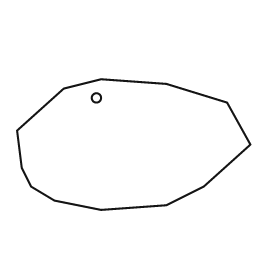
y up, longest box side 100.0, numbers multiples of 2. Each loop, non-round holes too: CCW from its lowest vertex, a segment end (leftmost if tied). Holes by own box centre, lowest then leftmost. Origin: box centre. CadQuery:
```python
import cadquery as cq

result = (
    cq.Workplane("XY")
    .moveTo(-14.0, -28.0)
    .lineTo(14.0, -26.0)
    .lineTo(30.0, -18.0)
    .lineTo(50.0, 0.0)
    .lineTo(40.0, 18.0)
    .lineTo(14.0, 26.0)
    .lineTo(-14.0, 28.0)
    .lineTo(-30.0, 24.0)
    .lineTo(-50.0, 6.0)
    .lineTo(-48.0, -10.0)
    .lineTo(-44.0, -18.0)
    .lineTo(-34.0, -24.0)
    .close()
    .moveTo(-16.0, 20.0)
    .circle(2.0)
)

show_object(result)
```